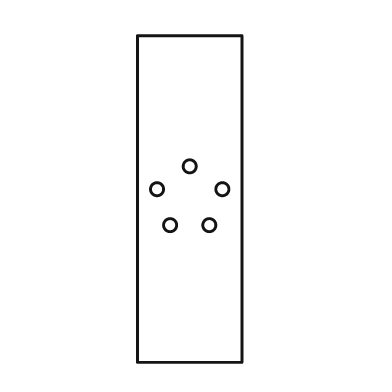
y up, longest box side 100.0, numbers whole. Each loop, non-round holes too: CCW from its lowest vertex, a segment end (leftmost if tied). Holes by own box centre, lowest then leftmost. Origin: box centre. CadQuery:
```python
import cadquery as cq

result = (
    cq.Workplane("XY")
    .moveTo(-16.0, -50.0)
    .lineTo(16.0, -50.0)
    .lineTo(16.0, 50.0)
    .lineTo(-16.0, 50.0)
    .close()
    .moveTo(-6.0, -8.0)
    .circle(2.0)
    .moveTo(6.0, -8.0)
    .circle(2.0)
    .moveTo(-10.0, 3.0)
    .circle(2.0)
    .moveTo(10.0, 3.0)
    .circle(2.0)
    .moveTo(0.0, 10.0)
    .circle(2.0)
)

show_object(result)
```